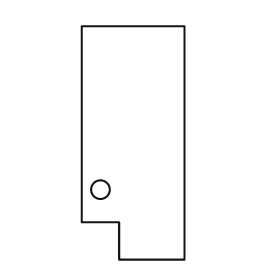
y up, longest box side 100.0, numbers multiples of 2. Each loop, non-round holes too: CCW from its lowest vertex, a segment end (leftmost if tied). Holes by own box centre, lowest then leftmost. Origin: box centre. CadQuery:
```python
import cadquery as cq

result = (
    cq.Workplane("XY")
    .moveTo(-6.0, -50.0)
    .lineTo(22.0, -50.0)
    .lineTo(22.0, 50.0)
    .lineTo(-22.0, 50.0)
    .lineTo(-22.0, -34.0)
    .lineTo(-6.0, -34.0)
    .close()
    .moveTo(-14.0, -20.0)
    .circle(4.0)
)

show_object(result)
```